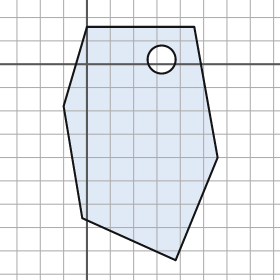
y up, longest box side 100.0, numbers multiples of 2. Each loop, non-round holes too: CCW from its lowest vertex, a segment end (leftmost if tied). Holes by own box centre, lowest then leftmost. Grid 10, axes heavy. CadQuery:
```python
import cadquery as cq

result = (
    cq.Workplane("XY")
    .moveTo(38.0, -84.0)
    .lineTo(56.0, -40.0)
    .lineTo(46.0, 16.0)
    .lineTo(0.0, 16.0)
    .lineTo(-10.0, -18.0)
    .lineTo(-2.0, -66.0)
    .close()
    .moveTo(32.0, 2.0)
    .circle(6.0)
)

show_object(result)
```